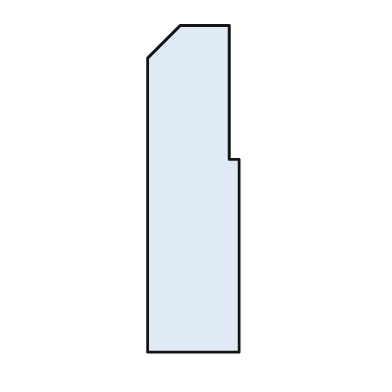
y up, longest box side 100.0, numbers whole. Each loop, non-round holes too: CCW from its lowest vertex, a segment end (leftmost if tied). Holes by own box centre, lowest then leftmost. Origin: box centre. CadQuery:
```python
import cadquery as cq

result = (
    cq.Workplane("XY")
    .moveTo(-14.0, -50.0)
    .lineTo(14.0, -50.0)
    .lineTo(14.0, 9.0)
    .lineTo(11.0, 9.0)
    .lineTo(11.0, 50.0)
    .lineTo(-4.0, 50.0)
    .lineTo(-14.0, 40.0)
    .close()
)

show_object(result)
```